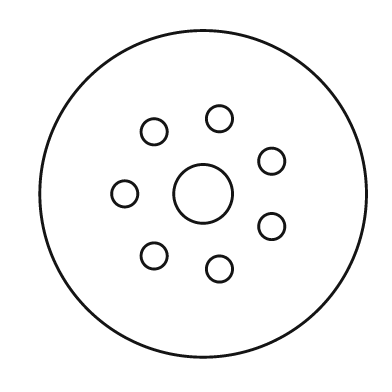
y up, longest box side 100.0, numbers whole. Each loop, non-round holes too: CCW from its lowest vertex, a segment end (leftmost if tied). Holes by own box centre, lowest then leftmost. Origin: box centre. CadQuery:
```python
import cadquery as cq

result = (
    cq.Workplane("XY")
    .moveTo(0.0, 0.0)
    .circle(50.0)
    .moveTo(5.0, -23.0)
    .circle(4.0)
    .moveTo(-15.0, -19.0)
    .circle(4.0)
    .moveTo(21.0, -10.0)
    .circle(4.0)
    .moveTo(-24.0, 0.0)
    .circle(4.0)
    .moveTo(0.0, 0.0)
    .circle(9.0)
    .moveTo(21.0, 10.0)
    .circle(4.0)
    .moveTo(-15.0, 19.0)
    .circle(4.0)
    .moveTo(5.0, 23.0)
    .circle(4.0)
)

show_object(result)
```